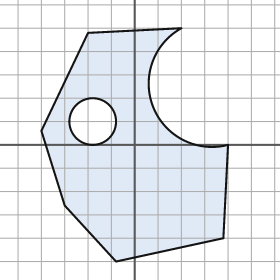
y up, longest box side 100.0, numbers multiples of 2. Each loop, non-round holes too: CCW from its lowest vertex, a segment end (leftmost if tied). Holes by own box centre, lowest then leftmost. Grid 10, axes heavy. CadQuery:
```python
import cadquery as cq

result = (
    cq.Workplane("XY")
    .moveTo(-8.0, -50.0)
    .lineTo(38.0, -40.0)
    .lineTo(40.0, 0.0)
    .threePointArc((8.0, 16.0), (20.0, 50.0))
    .lineTo(-20.0, 48.0)
    .lineTo(-40.0, 6.0)
    .lineTo(-30.0, -26.0)
    .close()
    .moveTo(-18.0, 10.0)
    .circle(10.0)
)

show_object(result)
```